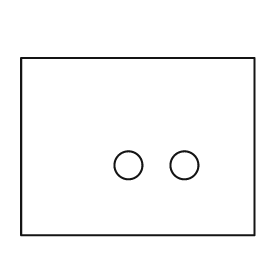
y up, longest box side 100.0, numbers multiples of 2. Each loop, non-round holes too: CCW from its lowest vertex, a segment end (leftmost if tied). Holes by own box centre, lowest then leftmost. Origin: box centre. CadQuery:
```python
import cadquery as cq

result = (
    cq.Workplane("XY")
    .moveTo(-50.0, -38.0)
    .lineTo(50.0, -38.0)
    .lineTo(50.0, 38.0)
    .lineTo(-50.0, 38.0)
    .close()
    .moveTo(-4.0, -8.0)
    .circle(6.0)
    .moveTo(20.0, -8.0)
    .circle(6.0)
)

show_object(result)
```